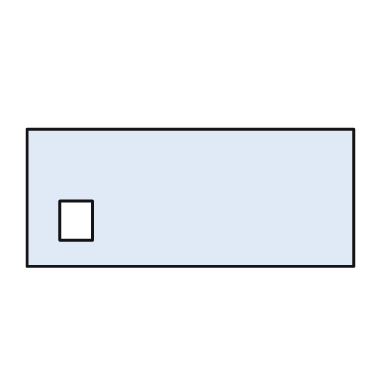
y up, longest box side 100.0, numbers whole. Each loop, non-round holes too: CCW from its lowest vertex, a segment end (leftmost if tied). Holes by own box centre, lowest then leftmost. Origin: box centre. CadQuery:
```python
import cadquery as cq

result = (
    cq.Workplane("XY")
    .moveTo(-50.0, -21.0)
    .lineTo(50.0, -21.0)
    .lineTo(50.0, 21.0)
    .lineTo(-50.0, 21.0)
    .close()
    .moveTo(-40.0, -13.0)
    .lineTo(-30.0, -13.0)
    .lineTo(-30.0, -1.0)
    .lineTo(-40.0, -1.0)
    .close()
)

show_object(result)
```